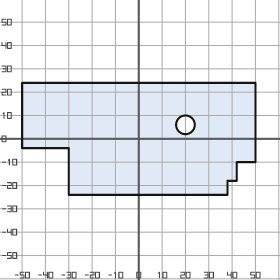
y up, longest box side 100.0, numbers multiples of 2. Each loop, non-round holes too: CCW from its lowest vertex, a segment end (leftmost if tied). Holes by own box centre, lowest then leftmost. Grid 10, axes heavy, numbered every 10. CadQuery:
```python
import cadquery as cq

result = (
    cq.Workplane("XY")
    .moveTo(-30.0, -24.0)
    .lineTo(38.0, -24.0)
    .lineTo(38.0, -18.0)
    .lineTo(42.0, -18.0)
    .lineTo(42.0, -10.0)
    .lineTo(50.0, -10.0)
    .lineTo(50.0, 24.0)
    .lineTo(-50.0, 24.0)
    .lineTo(-50.0, -4.0)
    .lineTo(-30.0, -4.0)
    .close()
    .moveTo(20.0, 6.0)
    .circle(4.0)
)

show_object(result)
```